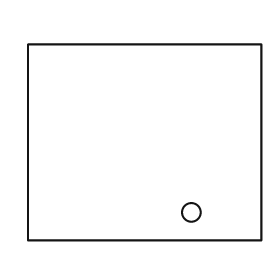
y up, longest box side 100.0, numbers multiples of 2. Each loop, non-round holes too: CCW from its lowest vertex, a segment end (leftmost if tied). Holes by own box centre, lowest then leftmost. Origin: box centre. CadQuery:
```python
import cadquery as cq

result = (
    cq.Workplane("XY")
    .moveTo(-50.0, -42.0)
    .lineTo(50.0, -42.0)
    .lineTo(50.0, 42.0)
    .lineTo(-50.0, 42.0)
    .close()
    .moveTo(20.0, -30.0)
    .circle(4.0)
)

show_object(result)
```